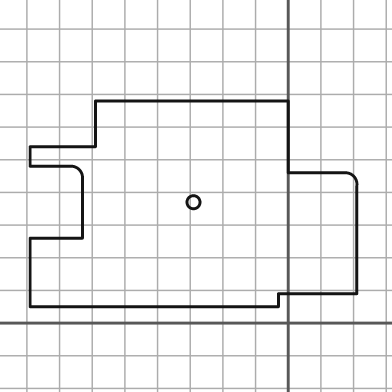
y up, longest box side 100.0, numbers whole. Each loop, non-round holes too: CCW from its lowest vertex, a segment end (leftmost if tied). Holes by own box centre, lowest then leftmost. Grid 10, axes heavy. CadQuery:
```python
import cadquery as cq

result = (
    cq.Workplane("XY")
    .moveTo(-79.0, 5.0)
    .lineTo(-3.0, 5.0)
    .lineTo(-3.0, 9.0)
    .lineTo(21.0, 9.0)
    .lineTo(21.0, 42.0)
    .threePointArc((20.0, 45.0), (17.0, 46.0))
    .lineTo(0.0, 46.0)
    .lineTo(0.0, 68.0)
    .lineTo(-59.0, 68.0)
    .lineTo(-59.0, 54.0)
    .lineTo(-79.0, 54.0)
    .lineTo(-79.0, 48.0)
    .lineTo(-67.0, 48.0)
    .threePointArc((-64.0, 47.0), (-63.0, 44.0))
    .lineTo(-63.0, 26.0)
    .lineTo(-79.0, 26.0)
    .close()
    .moveTo(-29.0, 37.0)
    .circle(2.0)
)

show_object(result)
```